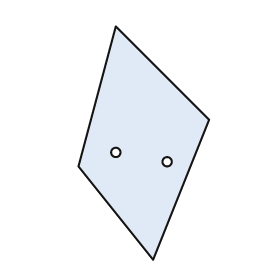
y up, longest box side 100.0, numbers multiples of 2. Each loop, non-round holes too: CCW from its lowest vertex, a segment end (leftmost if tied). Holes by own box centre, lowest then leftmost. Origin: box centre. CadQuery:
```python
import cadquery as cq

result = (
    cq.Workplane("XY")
    .moveTo(4.0, -50.0)
    .lineTo(28.0, 10.0)
    .lineTo(-12.0, 50.0)
    .lineTo(-28.0, -10.0)
    .close()
    .moveTo(10.0, -8.0)
    .circle(2.0)
    .moveTo(-12.0, -4.0)
    .circle(2.0)
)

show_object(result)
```